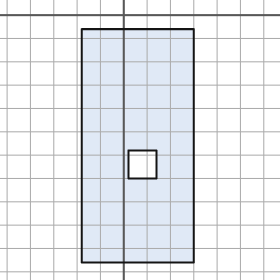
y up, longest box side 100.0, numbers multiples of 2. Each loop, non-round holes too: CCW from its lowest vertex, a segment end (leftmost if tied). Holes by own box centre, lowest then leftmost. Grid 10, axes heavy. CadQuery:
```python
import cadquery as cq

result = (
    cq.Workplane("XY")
    .moveTo(-18.0, -106.0)
    .lineTo(30.0, -106.0)
    .lineTo(30.0, -6.0)
    .lineTo(-18.0, -6.0)
    .close()
    .moveTo(2.0, -70.0)
    .lineTo(14.0, -70.0)
    .lineTo(14.0, -58.0)
    .lineTo(2.0, -58.0)
    .close()
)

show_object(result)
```